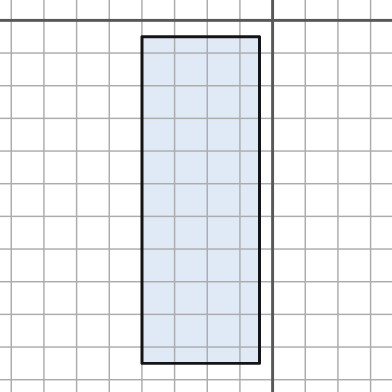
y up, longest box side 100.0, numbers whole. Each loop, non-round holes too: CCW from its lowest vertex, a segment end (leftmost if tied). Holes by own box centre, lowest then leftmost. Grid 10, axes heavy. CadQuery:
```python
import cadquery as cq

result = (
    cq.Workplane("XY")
    .moveTo(-40.0, -105.0)
    .lineTo(-4.0, -105.0)
    .lineTo(-4.0, -5.0)
    .lineTo(-40.0, -5.0)
    .close()
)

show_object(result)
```